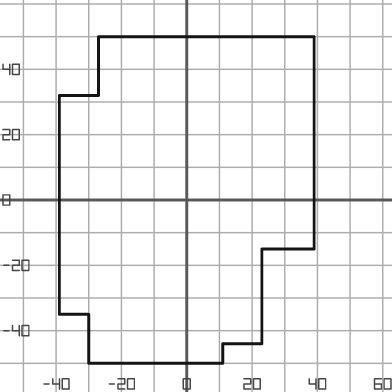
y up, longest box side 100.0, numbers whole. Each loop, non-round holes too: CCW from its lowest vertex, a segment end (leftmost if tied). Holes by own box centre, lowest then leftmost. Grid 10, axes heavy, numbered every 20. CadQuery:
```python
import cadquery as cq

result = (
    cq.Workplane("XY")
    .moveTo(-30.0, -50.0)
    .lineTo(11.0, -50.0)
    .lineTo(11.0, -44.0)
    .lineTo(23.0, -44.0)
    .lineTo(23.0, -15.0)
    .lineTo(39.0, -15.0)
    .lineTo(39.0, 50.0)
    .lineTo(-27.0, 50.0)
    .lineTo(-27.0, 32.0)
    .lineTo(-39.0, 32.0)
    .lineTo(-39.0, -35.0)
    .lineTo(-30.0, -35.0)
    .close()
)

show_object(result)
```